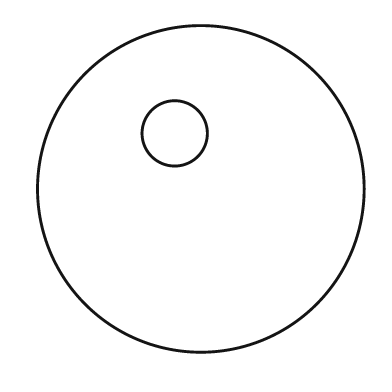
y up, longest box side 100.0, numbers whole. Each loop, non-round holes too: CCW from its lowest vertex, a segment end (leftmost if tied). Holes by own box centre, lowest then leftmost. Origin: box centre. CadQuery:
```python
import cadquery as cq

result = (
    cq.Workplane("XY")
    .moveTo(0.0, 0.0)
    .circle(50.0)
    .moveTo(-8.0, 17.0)
    .circle(10.0)
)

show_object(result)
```